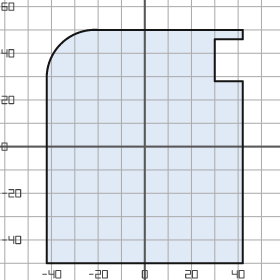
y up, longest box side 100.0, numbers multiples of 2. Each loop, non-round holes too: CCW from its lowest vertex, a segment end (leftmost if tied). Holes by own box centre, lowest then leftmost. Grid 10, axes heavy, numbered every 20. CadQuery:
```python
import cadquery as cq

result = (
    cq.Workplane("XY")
    .moveTo(-42.0, -50.0)
    .lineTo(42.0, -50.0)
    .lineTo(42.0, 28.0)
    .lineTo(30.0, 28.0)
    .lineTo(30.0, 46.0)
    .lineTo(42.0, 46.0)
    .lineTo(42.0, 50.0)
    .lineTo(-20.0, 50.0)
    .threePointArc((-36.0, 44.0), (-42.0, 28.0))
    .close()
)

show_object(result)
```